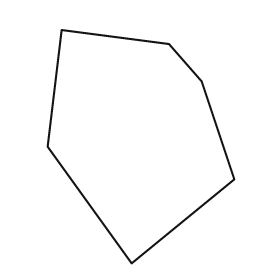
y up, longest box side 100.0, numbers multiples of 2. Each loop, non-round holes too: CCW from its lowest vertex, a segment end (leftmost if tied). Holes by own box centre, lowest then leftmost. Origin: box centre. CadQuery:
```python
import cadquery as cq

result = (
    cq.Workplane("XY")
    .moveTo(-4.0, -50.0)
    .lineTo(40.0, -14.0)
    .lineTo(26.0, 28.0)
    .lineTo(12.0, 44.0)
    .lineTo(-34.0, 50.0)
    .lineTo(-40.0, 0.0)
    .close()
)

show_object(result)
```